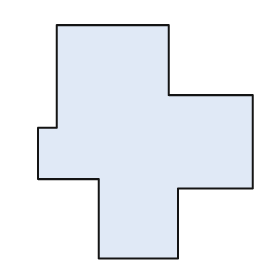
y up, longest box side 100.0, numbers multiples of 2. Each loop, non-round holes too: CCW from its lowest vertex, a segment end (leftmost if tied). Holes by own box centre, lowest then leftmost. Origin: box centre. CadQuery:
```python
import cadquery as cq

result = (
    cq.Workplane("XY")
    .moveTo(-20.0, -50.0)
    .lineTo(14.0, -50.0)
    .lineTo(14.0, -20.0)
    .lineTo(46.0, -20.0)
    .lineTo(46.0, 20.0)
    .lineTo(10.0, 20.0)
    .lineTo(10.0, 50.0)
    .lineTo(-38.0, 50.0)
    .lineTo(-38.0, 6.0)
    .lineTo(-46.0, 6.0)
    .lineTo(-46.0, -16.0)
    .lineTo(-20.0, -16.0)
    .close()
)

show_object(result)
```